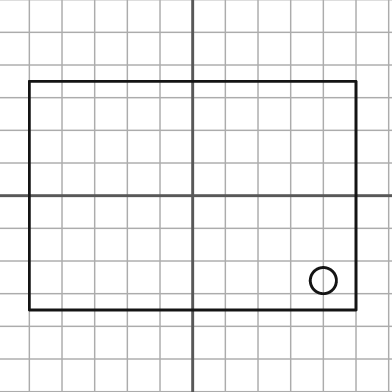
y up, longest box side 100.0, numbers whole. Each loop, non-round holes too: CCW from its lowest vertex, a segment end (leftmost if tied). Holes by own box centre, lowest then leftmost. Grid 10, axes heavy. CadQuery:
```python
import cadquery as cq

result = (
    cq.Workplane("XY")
    .moveTo(-50.0, -35.0)
    .lineTo(50.0, -35.0)
    .lineTo(50.0, 35.0)
    .lineTo(-50.0, 35.0)
    .close()
    .moveTo(40.0, -26.0)
    .circle(4.0)
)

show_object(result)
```